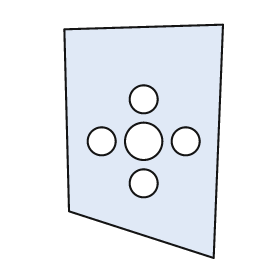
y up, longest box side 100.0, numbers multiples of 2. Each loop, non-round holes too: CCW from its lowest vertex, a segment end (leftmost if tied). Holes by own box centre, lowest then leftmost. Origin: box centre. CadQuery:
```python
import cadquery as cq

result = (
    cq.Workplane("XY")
    .moveTo(30.0, -50.0)
    .lineTo(34.0, 50.0)
    .lineTo(-34.0, 48.0)
    .lineTo(-32.0, -30.0)
    .close()
    .moveTo(0.0, -18.0)
    .circle(6.0)
    .moveTo(-18.0, 0.0)
    .circle(6.0)
    .moveTo(0.0, 0.0)
    .circle(8.0)
    .moveTo(18.0, 0.0)
    .circle(6.0)
    .moveTo(0.0, 18.0)
    .circle(6.0)
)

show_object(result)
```